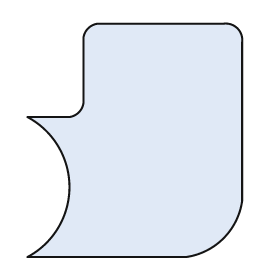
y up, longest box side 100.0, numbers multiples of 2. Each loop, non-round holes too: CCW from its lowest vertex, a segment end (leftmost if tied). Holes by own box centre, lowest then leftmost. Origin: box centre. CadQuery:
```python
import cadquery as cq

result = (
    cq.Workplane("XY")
    .moveTo(-46.0, -50.0)
    .lineTo(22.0, -50.0)
    .threePointArc((38.0, -42.0), (46.0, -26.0))
    .lineTo(46.0, 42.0)
    .threePointArc((44.0, 48.0), (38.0, 50.0))
    .lineTo(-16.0, 50.0)
    .threePointArc((-20.0, 48.0), (-22.0, 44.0))
    .lineTo(-22.0, 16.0)
    .threePointArc((-24.0, 12.0), (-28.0, 10.0))
    .lineTo(-46.0, 10.0)
    .threePointArc((-28.0, -20.0), (-46.0, -50.0))
    .close()
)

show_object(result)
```